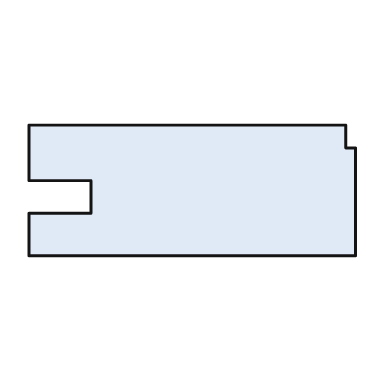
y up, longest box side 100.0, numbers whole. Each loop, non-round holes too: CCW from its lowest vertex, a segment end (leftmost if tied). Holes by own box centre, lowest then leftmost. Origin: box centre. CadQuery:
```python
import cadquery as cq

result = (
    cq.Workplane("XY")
    .moveTo(-50.0, -20.0)
    .lineTo(50.0, -20.0)
    .lineTo(50.0, 13.0)
    .lineTo(47.0, 13.0)
    .lineTo(47.0, 20.0)
    .lineTo(-50.0, 20.0)
    .lineTo(-50.0, 3.0)
    .lineTo(-31.0, 3.0)
    .lineTo(-31.0, -7.0)
    .lineTo(-50.0, -7.0)
    .close()
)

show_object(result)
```